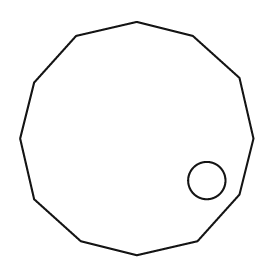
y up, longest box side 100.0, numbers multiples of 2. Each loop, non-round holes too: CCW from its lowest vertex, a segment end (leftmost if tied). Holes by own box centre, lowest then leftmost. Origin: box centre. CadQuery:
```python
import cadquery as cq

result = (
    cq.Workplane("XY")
    .moveTo(0.0, -50.0)
    .lineTo(26.0, -44.0)
    .lineTo(44.0, -24.0)
    .lineTo(50.0, 0.0)
    .lineTo(44.0, 26.0)
    .lineTo(24.0, 44.0)
    .lineTo(0.0, 50.0)
    .lineTo(-26.0, 44.0)
    .lineTo(-44.0, 24.0)
    .lineTo(-50.0, 0.0)
    .lineTo(-44.0, -26.0)
    .lineTo(-24.0, -44.0)
    .close()
    .moveTo(30.0, -18.0)
    .circle(8.0)
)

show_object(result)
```